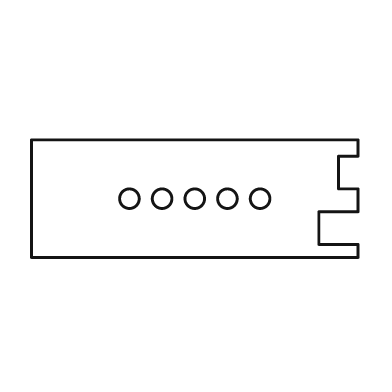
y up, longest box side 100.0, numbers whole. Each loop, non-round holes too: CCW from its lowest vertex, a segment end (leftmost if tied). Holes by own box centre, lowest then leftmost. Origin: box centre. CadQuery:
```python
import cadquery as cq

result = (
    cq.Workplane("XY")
    .moveTo(-50.0, -18.0)
    .lineTo(50.0, -18.0)
    .lineTo(50.0, -14.0)
    .lineTo(38.0, -14.0)
    .lineTo(38.0, -4.0)
    .lineTo(50.0, -4.0)
    .lineTo(50.0, 3.0)
    .lineTo(44.0, 3.0)
    .lineTo(44.0, 13.0)
    .lineTo(50.0, 13.0)
    .lineTo(50.0, 18.0)
    .lineTo(-50.0, 18.0)
    .close()
    .moveTo(-20.0, 0.0)
    .circle(3.0)
    .moveTo(-10.0, 0.0)
    .circle(3.0)
    .moveTo(0.0, 0.0)
    .circle(3.0)
    .moveTo(10.0, 0.0)
    .circle(3.0)
    .moveTo(20.0, 0.0)
    .circle(3.0)
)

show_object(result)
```